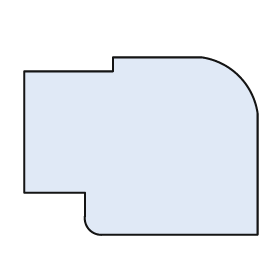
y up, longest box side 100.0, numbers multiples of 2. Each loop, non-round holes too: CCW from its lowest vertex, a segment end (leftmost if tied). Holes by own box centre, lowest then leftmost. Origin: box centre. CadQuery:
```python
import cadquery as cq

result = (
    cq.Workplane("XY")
    .moveTo(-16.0, -38.0)
    .lineTo(50.0, -38.0)
    .lineTo(50.0, 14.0)
    .threePointArc((42.0, 30.0), (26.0, 38.0))
    .lineTo(-12.0, 38.0)
    .lineTo(-12.0, 32.0)
    .lineTo(-50.0, 32.0)
    .lineTo(-50.0, -20.0)
    .lineTo(-24.0, -20.0)
    .lineTo(-24.0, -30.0)
    .threePointArc((-22.0, -36.0), (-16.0, -38.0))
    .close()
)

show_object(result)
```